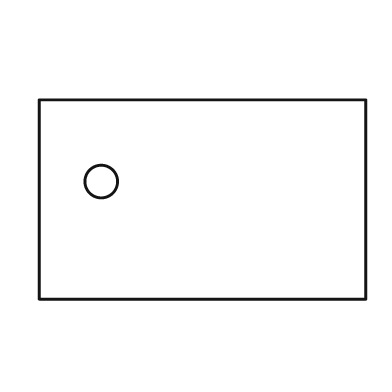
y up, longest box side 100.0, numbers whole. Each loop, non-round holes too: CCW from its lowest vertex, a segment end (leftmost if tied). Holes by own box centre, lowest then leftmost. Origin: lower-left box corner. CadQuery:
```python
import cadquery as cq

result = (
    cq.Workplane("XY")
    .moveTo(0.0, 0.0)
    .lineTo(100.0, 0.0)
    .lineTo(100.0, 61.0)
    .lineTo(0.0, 61.0)
    .close()
    .moveTo(19.0, 36.0)
    .circle(5.0)
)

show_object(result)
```